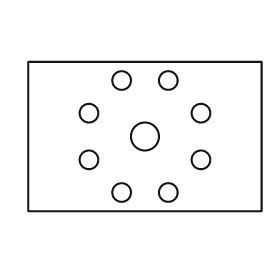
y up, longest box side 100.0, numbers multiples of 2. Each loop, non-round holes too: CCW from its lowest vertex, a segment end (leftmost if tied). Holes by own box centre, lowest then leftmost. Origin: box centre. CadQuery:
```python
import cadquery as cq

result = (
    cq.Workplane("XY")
    .moveTo(-50.0, -32.0)
    .lineTo(50.0, -32.0)
    .lineTo(50.0, 32.0)
    .lineTo(-50.0, 32.0)
    .close()
    .moveTo(-10.0, -24.0)
    .circle(4.0)
    .moveTo(10.0, -24.0)
    .circle(4.0)
    .moveTo(-24.0, -10.0)
    .circle(4.0)
    .moveTo(24.0, -10.0)
    .circle(4.0)
    .moveTo(0.0, 0.0)
    .circle(6.0)
    .moveTo(-24.0, 10.0)
    .circle(4.0)
    .moveTo(24.0, 10.0)
    .circle(4.0)
    .moveTo(-10.0, 24.0)
    .circle(4.0)
    .moveTo(10.0, 24.0)
    .circle(4.0)
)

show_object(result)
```